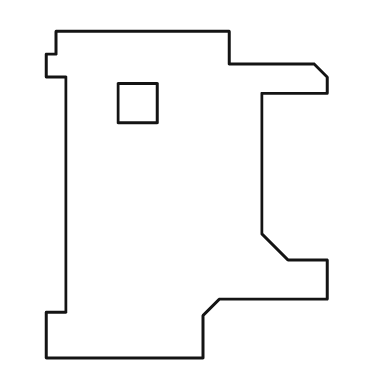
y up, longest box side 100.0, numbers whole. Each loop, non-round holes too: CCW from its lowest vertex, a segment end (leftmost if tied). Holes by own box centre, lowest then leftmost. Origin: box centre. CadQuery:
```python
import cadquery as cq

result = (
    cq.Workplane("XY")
    .moveTo(-43.0, -50.0)
    .lineTo(5.0, -50.0)
    .lineTo(5.0, -37.0)
    .lineTo(10.0, -32.0)
    .lineTo(43.0, -32.0)
    .lineTo(43.0, -20.0)
    .lineTo(31.0, -20.0)
    .lineTo(23.0, -12.0)
    .lineTo(23.0, 31.0)
    .lineTo(43.0, 31.0)
    .lineTo(43.0, 36.0)
    .lineTo(39.0, 40.0)
    .lineTo(13.0, 40.0)
    .lineTo(13.0, 50.0)
    .lineTo(-40.0, 50.0)
    .lineTo(-40.0, 43.0)
    .lineTo(-43.0, 43.0)
    .lineTo(-43.0, 36.0)
    .lineTo(-37.0, 36.0)
    .lineTo(-37.0, -36.0)
    .lineTo(-43.0, -36.0)
    .close()
    .moveTo(-21.0, 22.0)
    .lineTo(-9.0, 22.0)
    .lineTo(-9.0, 34.0)
    .lineTo(-21.0, 34.0)
    .close()
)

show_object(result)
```